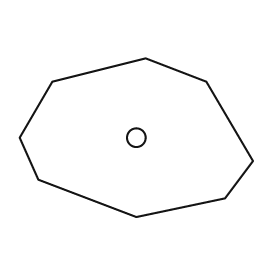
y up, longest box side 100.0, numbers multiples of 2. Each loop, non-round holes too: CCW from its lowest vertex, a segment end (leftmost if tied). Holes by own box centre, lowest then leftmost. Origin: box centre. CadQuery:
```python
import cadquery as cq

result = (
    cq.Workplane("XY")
    .moveTo(0.0, -34.0)
    .lineTo(38.0, -26.0)
    .lineTo(50.0, -10.0)
    .lineTo(30.0, 24.0)
    .lineTo(4.0, 34.0)
    .lineTo(-36.0, 24.0)
    .lineTo(-50.0, 0.0)
    .lineTo(-42.0, -18.0)
    .close()
    .moveTo(0.0, 0.0)
    .circle(4.0)
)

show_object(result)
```